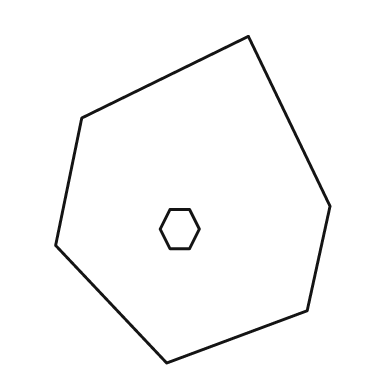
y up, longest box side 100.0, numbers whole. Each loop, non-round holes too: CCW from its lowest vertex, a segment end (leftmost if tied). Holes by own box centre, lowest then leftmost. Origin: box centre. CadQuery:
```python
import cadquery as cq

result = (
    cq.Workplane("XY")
    .moveTo(-8.0, -50.0)
    .lineTo(35.0, -34.0)
    .lineTo(42.0, -2.0)
    .lineTo(17.0, 50.0)
    .lineTo(-34.0, 25.0)
    .lineTo(-42.0, -14.0)
    .close()
    .moveTo(-7.0, -15.0)
    .lineTo(-1.0, -15.0)
    .lineTo(2.0, -9.0)
    .lineTo(-1.0, -3.0)
    .lineTo(-7.0, -3.0)
    .lineTo(-10.0, -9.0)
    .close()
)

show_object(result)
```